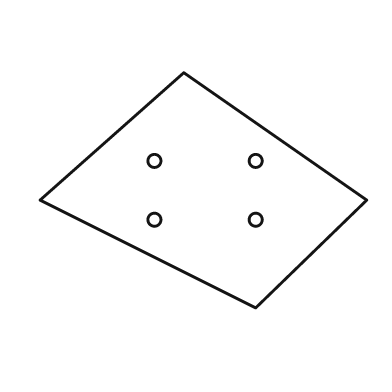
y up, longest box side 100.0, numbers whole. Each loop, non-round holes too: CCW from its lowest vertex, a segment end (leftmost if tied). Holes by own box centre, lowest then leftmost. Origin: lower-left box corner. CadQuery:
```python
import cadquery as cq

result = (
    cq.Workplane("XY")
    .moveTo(66.0, 0.0)
    .lineTo(100.0, 33.0)
    .lineTo(44.0, 72.0)
    .lineTo(0.0, 33.0)
    .close()
    .moveTo(35.0, 27.0)
    .circle(2.0)
    .moveTo(66.0, 27.0)
    .circle(2.0)
    .moveTo(35.0, 45.0)
    .circle(2.0)
    .moveTo(66.0, 45.0)
    .circle(2.0)
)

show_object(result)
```